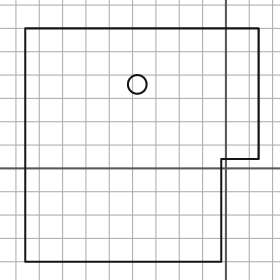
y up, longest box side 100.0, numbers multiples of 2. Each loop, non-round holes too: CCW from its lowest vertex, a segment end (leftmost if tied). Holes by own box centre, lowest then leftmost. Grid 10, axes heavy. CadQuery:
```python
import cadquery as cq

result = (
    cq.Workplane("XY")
    .moveTo(-86.0, -40.0)
    .lineTo(-2.0, -40.0)
    .lineTo(-2.0, 4.0)
    .lineTo(14.0, 4.0)
    .lineTo(14.0, 60.0)
    .lineTo(-86.0, 60.0)
    .close()
    .moveTo(-38.0, 36.0)
    .circle(4.0)
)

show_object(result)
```